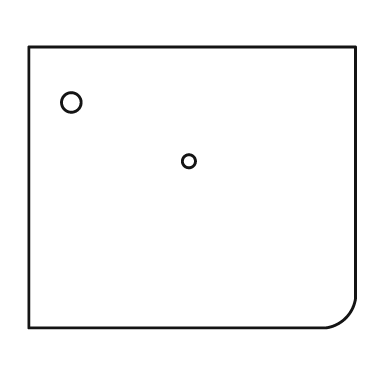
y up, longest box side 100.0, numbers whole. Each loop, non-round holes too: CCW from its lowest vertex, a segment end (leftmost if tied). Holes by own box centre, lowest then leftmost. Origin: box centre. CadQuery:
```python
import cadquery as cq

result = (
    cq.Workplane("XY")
    .moveTo(-50.0, -43.0)
    .lineTo(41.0, -43.0)
    .threePointArc((47.0, -40.0), (50.0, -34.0))
    .lineTo(50.0, 43.0)
    .lineTo(-50.0, 43.0)
    .close()
    .moveTo(-1.0, 8.0)
    .circle(2.0)
    .moveTo(-37.0, 26.0)
    .circle(3.0)
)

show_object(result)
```